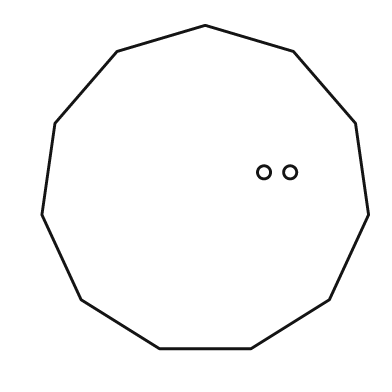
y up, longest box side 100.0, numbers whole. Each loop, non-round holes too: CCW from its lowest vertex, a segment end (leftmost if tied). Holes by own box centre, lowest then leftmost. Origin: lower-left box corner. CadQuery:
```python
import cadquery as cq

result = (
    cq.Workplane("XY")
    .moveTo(36.0, 0.0)
    .lineTo(64.0, 0.0)
    .lineTo(88.0, 15.0)
    .lineTo(100.0, 41.0)
    .lineTo(96.0, 69.0)
    .lineTo(77.0, 91.0)
    .lineTo(50.0, 99.0)
    .lineTo(23.0, 91.0)
    .lineTo(4.0, 69.0)
    .lineTo(0.0, 41.0)
    .lineTo(12.0, 15.0)
    .close()
    .moveTo(68.0, 54.0)
    .circle(2.0)
    .moveTo(76.0, 54.0)
    .circle(2.0)
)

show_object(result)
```